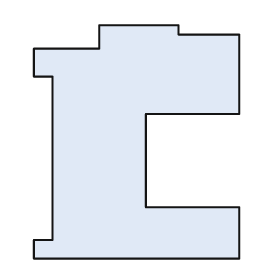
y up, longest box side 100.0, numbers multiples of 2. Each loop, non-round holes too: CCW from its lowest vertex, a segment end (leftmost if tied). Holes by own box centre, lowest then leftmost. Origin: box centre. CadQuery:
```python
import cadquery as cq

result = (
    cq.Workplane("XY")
    .moveTo(-44.0, -50.0)
    .lineTo(44.0, -50.0)
    .lineTo(44.0, -28.0)
    .lineTo(4.0, -28.0)
    .lineTo(4.0, 12.0)
    .lineTo(44.0, 12.0)
    .lineTo(44.0, 46.0)
    .lineTo(18.0, 46.0)
    .lineTo(18.0, 50.0)
    .lineTo(-16.0, 50.0)
    .lineTo(-16.0, 40.0)
    .lineTo(-44.0, 40.0)
    .lineTo(-44.0, 28.0)
    .lineTo(-36.0, 28.0)
    .lineTo(-36.0, -42.0)
    .lineTo(-44.0, -42.0)
    .close()
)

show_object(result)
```